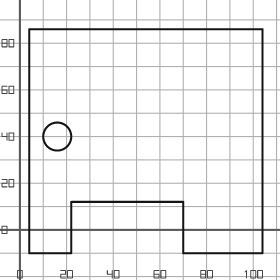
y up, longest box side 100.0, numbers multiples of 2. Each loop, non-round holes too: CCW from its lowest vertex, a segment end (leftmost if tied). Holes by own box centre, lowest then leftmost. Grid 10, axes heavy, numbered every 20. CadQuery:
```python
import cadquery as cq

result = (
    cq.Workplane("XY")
    .moveTo(4.0, -10.0)
    .lineTo(22.0, -10.0)
    .lineTo(22.0, 12.0)
    .lineTo(70.0, 12.0)
    .lineTo(70.0, -10.0)
    .lineTo(104.0, -10.0)
    .lineTo(104.0, 86.0)
    .lineTo(4.0, 86.0)
    .close()
    .moveTo(16.0, 40.0)
    .circle(6.0)
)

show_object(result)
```